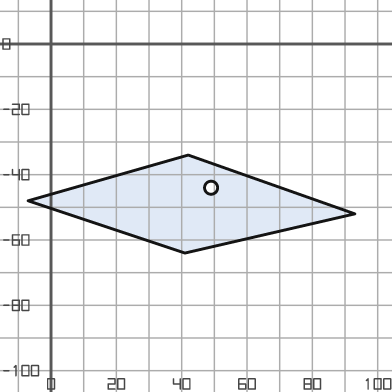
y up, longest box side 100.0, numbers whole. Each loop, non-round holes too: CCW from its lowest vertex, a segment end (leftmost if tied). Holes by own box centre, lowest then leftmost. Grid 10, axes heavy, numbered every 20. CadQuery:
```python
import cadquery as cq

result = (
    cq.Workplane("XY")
    .moveTo(41.0, -64.0)
    .lineTo(93.0, -52.0)
    .lineTo(42.0, -34.0)
    .lineTo(-7.0, -48.0)
    .close()
    .moveTo(49.0, -44.0)
    .circle(2.0)
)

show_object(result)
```